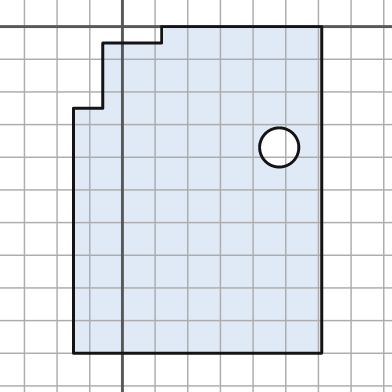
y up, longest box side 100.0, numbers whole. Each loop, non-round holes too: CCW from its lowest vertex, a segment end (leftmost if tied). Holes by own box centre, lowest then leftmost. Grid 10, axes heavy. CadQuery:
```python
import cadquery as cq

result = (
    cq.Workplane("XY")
    .moveTo(-15.0, -100.0)
    .lineTo(61.0, -100.0)
    .lineTo(61.0, 0.0)
    .lineTo(12.0, 0.0)
    .lineTo(12.0, -5.0)
    .lineTo(-6.0, -5.0)
    .lineTo(-6.0, -25.0)
    .lineTo(-15.0, -25.0)
    .close()
    .moveTo(48.0, -37.0)
    .circle(6.0)
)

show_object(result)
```